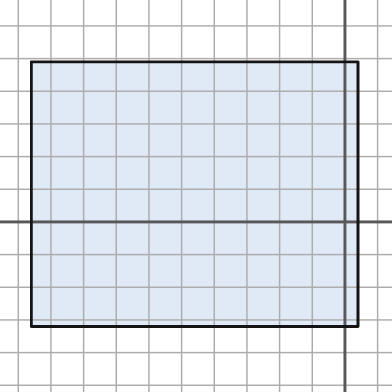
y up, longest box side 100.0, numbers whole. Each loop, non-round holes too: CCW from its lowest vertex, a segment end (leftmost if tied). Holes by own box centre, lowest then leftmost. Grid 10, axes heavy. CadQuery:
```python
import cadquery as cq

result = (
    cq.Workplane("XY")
    .moveTo(-96.0, -32.0)
    .lineTo(4.0, -32.0)
    .lineTo(4.0, 49.0)
    .lineTo(-96.0, 49.0)
    .close()
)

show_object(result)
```